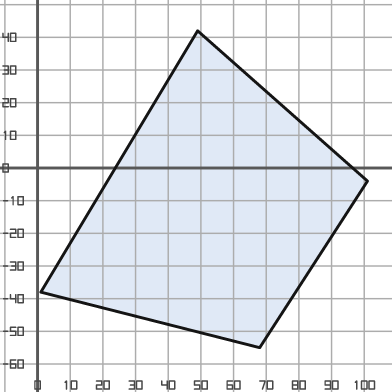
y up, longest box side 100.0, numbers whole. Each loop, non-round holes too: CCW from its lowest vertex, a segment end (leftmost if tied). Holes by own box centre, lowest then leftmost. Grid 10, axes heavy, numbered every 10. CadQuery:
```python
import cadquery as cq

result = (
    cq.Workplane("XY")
    .moveTo(68.0, -55.0)
    .lineTo(101.0, -4.0)
    .lineTo(49.0, 42.0)
    .lineTo(1.0, -38.0)
    .close()
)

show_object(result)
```